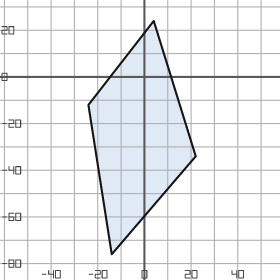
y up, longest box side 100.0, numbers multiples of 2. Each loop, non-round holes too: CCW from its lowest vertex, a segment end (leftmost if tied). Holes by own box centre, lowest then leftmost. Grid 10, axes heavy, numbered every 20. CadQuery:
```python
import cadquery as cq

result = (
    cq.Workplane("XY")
    .moveTo(-14.0, -76.0)
    .lineTo(22.0, -34.0)
    .lineTo(4.0, 24.0)
    .lineTo(-24.0, -12.0)
    .close()
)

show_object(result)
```